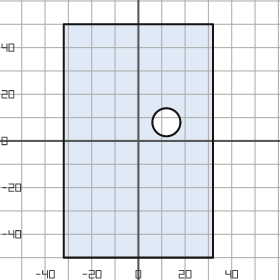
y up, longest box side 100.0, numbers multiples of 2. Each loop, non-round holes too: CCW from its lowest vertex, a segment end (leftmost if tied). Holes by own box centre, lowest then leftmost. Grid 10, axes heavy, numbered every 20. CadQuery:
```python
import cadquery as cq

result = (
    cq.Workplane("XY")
    .moveTo(-32.0, -50.0)
    .lineTo(32.0, -50.0)
    .lineTo(32.0, 50.0)
    .lineTo(-32.0, 50.0)
    .close()
    .moveTo(12.0, 8.0)
    .circle(6.0)
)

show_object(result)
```